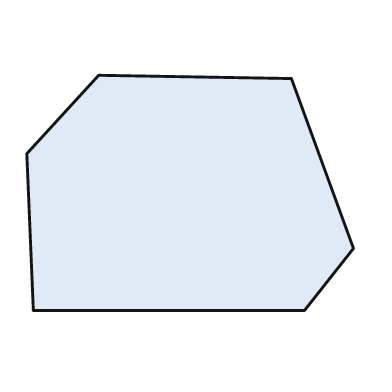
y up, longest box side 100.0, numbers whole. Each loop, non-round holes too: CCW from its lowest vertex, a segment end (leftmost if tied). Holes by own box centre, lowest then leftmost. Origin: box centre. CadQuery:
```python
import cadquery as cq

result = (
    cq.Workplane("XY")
    .moveTo(-48.0, -36.0)
    .lineTo(35.0, -36.0)
    .lineTo(50.0, -17.0)
    .lineTo(31.0, 35.0)
    .lineTo(-28.0, 36.0)
    .lineTo(-50.0, 12.0)
    .close()
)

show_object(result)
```